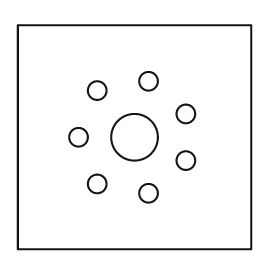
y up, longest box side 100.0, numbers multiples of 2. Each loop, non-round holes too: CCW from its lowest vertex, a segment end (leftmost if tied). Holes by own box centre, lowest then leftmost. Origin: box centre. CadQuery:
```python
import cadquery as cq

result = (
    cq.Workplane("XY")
    .moveTo(-50.0, -48.0)
    .lineTo(50.0, -48.0)
    .lineTo(50.0, 48.0)
    .lineTo(-50.0, 48.0)
    .close()
    .moveTo(6.0, -24.0)
    .circle(4.0)
    .moveTo(-16.0, -20.0)
    .circle(4.0)
    .moveTo(22.0, -10.0)
    .circle(4.0)
    .moveTo(-24.0, 0.0)
    .circle(4.0)
    .moveTo(0.0, 0.0)
    .circle(10.0)
    .moveTo(22.0, 10.0)
    .circle(4.0)
    .moveTo(-16.0, 20.0)
    .circle(4.0)
    .moveTo(6.0, 24.0)
    .circle(4.0)
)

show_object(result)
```